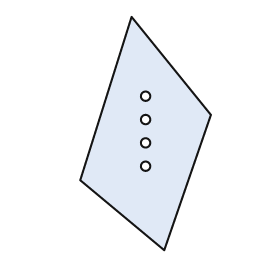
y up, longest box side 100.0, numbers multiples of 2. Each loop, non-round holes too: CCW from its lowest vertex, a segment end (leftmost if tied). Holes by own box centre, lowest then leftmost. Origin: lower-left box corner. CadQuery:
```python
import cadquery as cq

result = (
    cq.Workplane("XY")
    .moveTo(36.0, 0.0)
    .lineTo(56.0, 58.0)
    .lineTo(22.0, 100.0)
    .lineTo(0.0, 30.0)
    .close()
    .moveTo(28.0, 36.0)
    .circle(2.0)
    .moveTo(28.0, 46.0)
    .circle(2.0)
    .moveTo(28.0, 56.0)
    .circle(2.0)
    .moveTo(28.0, 66.0)
    .circle(2.0)
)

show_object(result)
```